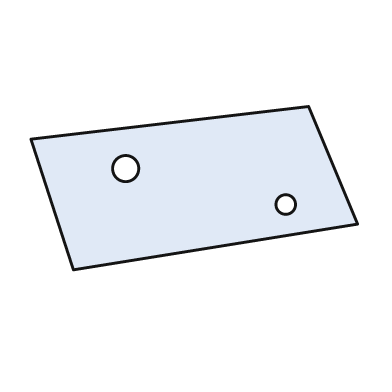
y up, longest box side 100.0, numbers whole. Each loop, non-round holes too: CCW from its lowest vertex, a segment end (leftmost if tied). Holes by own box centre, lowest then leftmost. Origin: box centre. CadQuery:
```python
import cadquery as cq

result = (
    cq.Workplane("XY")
    .moveTo(-37.0, -25.0)
    .lineTo(50.0, -11.0)
    .lineTo(35.0, 25.0)
    .lineTo(-50.0, 15.0)
    .close()
    .moveTo(28.0, -5.0)
    .circle(3.0)
    .moveTo(-21.0, 6.0)
    .circle(4.0)
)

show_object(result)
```